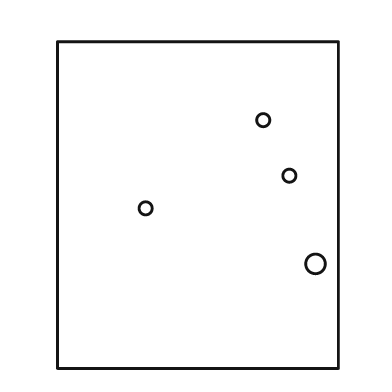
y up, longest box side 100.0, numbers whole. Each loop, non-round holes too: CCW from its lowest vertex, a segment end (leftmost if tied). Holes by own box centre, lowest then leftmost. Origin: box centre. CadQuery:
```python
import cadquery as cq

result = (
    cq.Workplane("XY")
    .moveTo(-43.0, -50.0)
    .lineTo(43.0, -50.0)
    .lineTo(43.0, 50.0)
    .lineTo(-43.0, 50.0)
    .close()
    .moveTo(36.0, -18.0)
    .circle(3.0)
    .moveTo(-16.0, -1.0)
    .circle(2.0)
    .moveTo(28.0, 9.0)
    .circle(2.0)
    .moveTo(20.0, 26.0)
    .circle(2.0)
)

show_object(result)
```